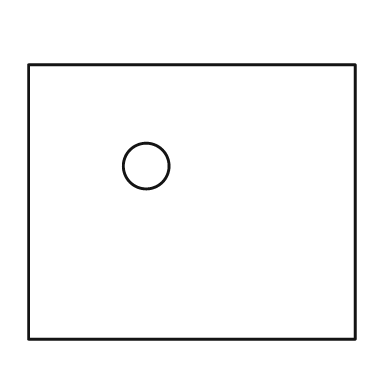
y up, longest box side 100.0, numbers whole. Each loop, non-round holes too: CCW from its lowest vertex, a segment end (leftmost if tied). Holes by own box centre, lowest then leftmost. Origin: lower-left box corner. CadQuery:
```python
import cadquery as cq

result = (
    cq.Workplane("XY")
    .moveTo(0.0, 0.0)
    .lineTo(100.0, 0.0)
    .lineTo(100.0, 84.0)
    .lineTo(0.0, 84.0)
    .close()
    .moveTo(36.0, 53.0)
    .circle(7.0)
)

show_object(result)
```